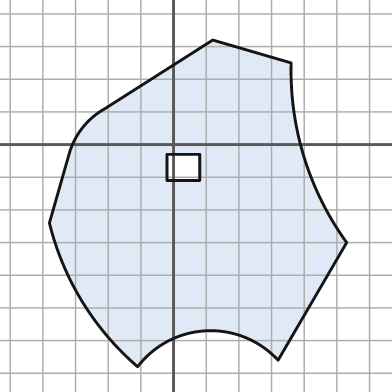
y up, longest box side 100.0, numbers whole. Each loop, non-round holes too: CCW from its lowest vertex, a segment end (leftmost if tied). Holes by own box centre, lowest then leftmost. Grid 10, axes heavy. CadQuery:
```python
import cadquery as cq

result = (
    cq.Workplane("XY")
    .moveTo(-11.0, -68.0)
    .threePointArc((10.0, -57.0), (32.0, -66.0))
    .lineTo(53.0, -30.0)
    .threePointArc((40.0, -4.0), (36.0, 25.0))
    .lineTo(12.0, 32.0)
    .lineTo(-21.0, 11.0)
    .threePointArc((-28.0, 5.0), (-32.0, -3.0))
    .lineTo(-38.0, -24.0)
    .threePointArc((-28.0, -48.0), (-11.0, -68.0))
    .close()
    .moveTo(-2.0, -11.0)
    .lineTo(8.0, -11.0)
    .lineTo(8.0, -3.0)
    .lineTo(-2.0, -3.0)
    .close()
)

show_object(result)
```